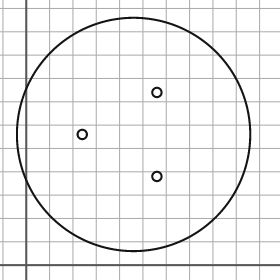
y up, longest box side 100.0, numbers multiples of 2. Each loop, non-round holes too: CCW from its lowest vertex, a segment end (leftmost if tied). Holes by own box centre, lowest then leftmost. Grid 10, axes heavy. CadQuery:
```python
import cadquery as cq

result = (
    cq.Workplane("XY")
    .moveTo(46.0, 56.0)
    .circle(50.0)
    .moveTo(56.0, 38.0)
    .circle(2.0)
    .moveTo(24.0, 56.0)
    .circle(2.0)
    .moveTo(56.0, 74.0)
    .circle(2.0)
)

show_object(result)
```